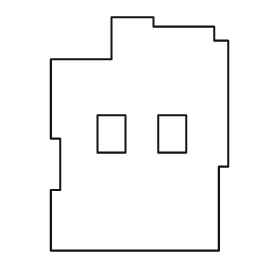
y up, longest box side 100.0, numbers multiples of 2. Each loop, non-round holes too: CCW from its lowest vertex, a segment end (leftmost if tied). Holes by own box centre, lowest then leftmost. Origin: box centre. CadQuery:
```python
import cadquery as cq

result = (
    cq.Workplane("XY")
    .moveTo(-38.0, -50.0)
    .lineTo(34.0, -50.0)
    .lineTo(34.0, -14.0)
    .lineTo(38.0, -14.0)
    .lineTo(38.0, 40.0)
    .lineTo(32.0, 40.0)
    .lineTo(32.0, 46.0)
    .lineTo(6.0, 46.0)
    .lineTo(6.0, 50.0)
    .lineTo(-12.0, 50.0)
    .lineTo(-12.0, 32.0)
    .lineTo(-38.0, 32.0)
    .lineTo(-38.0, -2.0)
    .lineTo(-34.0, -2.0)
    .lineTo(-34.0, -24.0)
    .lineTo(-38.0, -24.0)
    .close()
    .moveTo(-18.0, -8.0)
    .lineTo(-6.0, -8.0)
    .lineTo(-6.0, 8.0)
    .lineTo(-18.0, 8.0)
    .close()
    .moveTo(8.0, -8.0)
    .lineTo(20.0, -8.0)
    .lineTo(20.0, 8.0)
    .lineTo(8.0, 8.0)
    .close()
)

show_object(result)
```